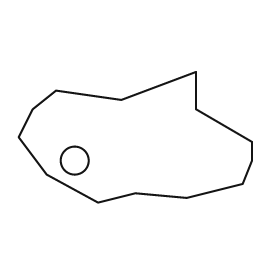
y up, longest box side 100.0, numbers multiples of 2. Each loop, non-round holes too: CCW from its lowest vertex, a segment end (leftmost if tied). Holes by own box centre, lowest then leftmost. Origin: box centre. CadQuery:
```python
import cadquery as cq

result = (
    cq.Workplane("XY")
    .moveTo(-16.0, -28.0)
    .lineTo(0.0, -24.0)
    .lineTo(22.0, -26.0)
    .lineTo(46.0, -20.0)
    .lineTo(50.0, -10.0)
    .lineTo(50.0, -2.0)
    .lineTo(26.0, 12.0)
    .lineTo(26.0, 28.0)
    .lineTo(-6.0, 16.0)
    .lineTo(-34.0, 20.0)
    .lineTo(-44.0, 12.0)
    .lineTo(-50.0, 0.0)
    .lineTo(-38.0, -16.0)
    .close()
    .moveTo(-26.0, -10.0)
    .circle(6.0)
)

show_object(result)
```